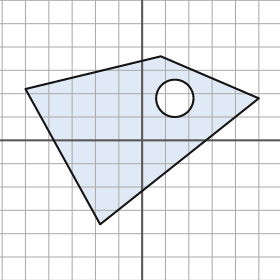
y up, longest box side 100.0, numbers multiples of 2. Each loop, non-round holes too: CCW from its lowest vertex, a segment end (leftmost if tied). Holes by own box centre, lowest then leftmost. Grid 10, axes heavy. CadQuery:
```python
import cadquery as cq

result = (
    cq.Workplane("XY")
    .moveTo(-18.0, -36.0)
    .lineTo(50.0, 18.0)
    .lineTo(8.0, 36.0)
    .lineTo(-50.0, 22.0)
    .close()
    .moveTo(14.0, 18.0)
    .circle(8.0)
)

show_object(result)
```